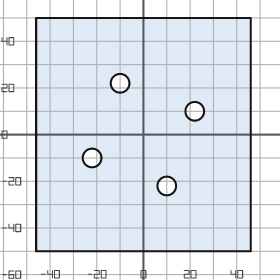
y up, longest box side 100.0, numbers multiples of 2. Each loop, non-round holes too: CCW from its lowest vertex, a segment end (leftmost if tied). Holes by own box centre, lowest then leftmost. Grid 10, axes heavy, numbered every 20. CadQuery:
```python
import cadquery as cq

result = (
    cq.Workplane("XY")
    .moveTo(-46.0, -50.0)
    .lineTo(46.0, -50.0)
    .lineTo(46.0, 50.0)
    .lineTo(-46.0, 50.0)
    .close()
    .moveTo(10.0, -22.0)
    .circle(4.0)
    .moveTo(-22.0, -10.0)
    .circle(4.0)
    .moveTo(22.0, 10.0)
    .circle(4.0)
    .moveTo(-10.0, 22.0)
    .circle(4.0)
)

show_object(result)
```